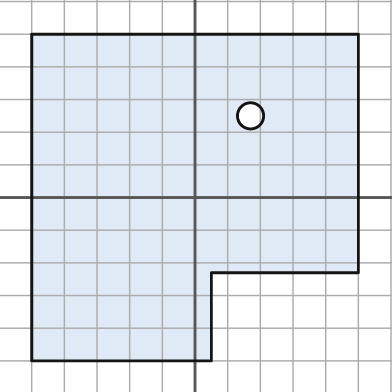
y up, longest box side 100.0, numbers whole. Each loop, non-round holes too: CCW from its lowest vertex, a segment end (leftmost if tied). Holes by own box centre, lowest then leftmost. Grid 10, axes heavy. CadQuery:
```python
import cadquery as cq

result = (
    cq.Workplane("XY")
    .moveTo(-50.0, -50.0)
    .lineTo(5.0, -50.0)
    .lineTo(5.0, -23.0)
    .lineTo(50.0, -23.0)
    .lineTo(50.0, 50.0)
    .lineTo(-50.0, 50.0)
    .close()
    .moveTo(17.0, 25.0)
    .circle(4.0)
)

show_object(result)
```